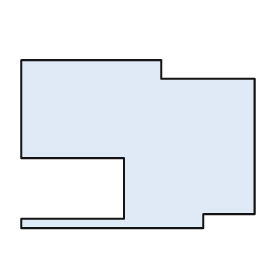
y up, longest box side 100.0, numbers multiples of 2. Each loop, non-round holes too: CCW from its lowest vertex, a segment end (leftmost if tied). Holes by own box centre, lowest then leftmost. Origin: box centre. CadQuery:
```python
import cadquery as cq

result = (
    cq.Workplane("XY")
    .moveTo(-50.0, -36.0)
    .lineTo(28.0, -36.0)
    .lineTo(28.0, -30.0)
    .lineTo(50.0, -30.0)
    .lineTo(50.0, 28.0)
    .lineTo(10.0, 28.0)
    .lineTo(10.0, 36.0)
    .lineTo(-50.0, 36.0)
    .lineTo(-50.0, -6.0)
    .lineTo(-6.0, -6.0)
    .lineTo(-6.0, -32.0)
    .lineTo(-50.0, -32.0)
    .close()
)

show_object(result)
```